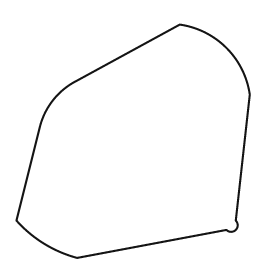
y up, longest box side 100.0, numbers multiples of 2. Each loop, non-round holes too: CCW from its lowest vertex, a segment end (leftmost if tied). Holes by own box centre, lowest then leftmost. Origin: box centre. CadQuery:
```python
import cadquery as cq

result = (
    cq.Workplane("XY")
    .moveTo(-24.0, -50.0)
    .lineTo(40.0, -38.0)
    .threePointArc((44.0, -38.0), (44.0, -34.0))
    .lineTo(50.0, 20.0)
    .threePointArc((40.0, 40.0), (20.0, 50.0))
    .lineTo(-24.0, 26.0)
    .threePointArc((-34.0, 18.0), (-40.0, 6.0))
    .lineTo(-50.0, -34.0)
    .threePointArc((-38.0, -44.0), (-24.0, -50.0))
    .close()
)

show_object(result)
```